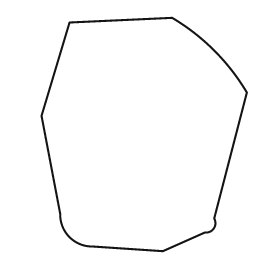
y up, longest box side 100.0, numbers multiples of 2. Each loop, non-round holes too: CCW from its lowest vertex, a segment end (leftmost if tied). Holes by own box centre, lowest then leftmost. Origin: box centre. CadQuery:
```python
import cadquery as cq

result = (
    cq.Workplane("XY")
    .moveTo(8.0, -50.0)
    .lineTo(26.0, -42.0)
    .threePointArc((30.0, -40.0), (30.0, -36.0))
    .lineTo(44.0, 18.0)
    .threePointArc((30.0, 36.0), (12.0, 50.0))
    .lineTo(-32.0, 48.0)
    .lineTo(-44.0, 8.0)
    .lineTo(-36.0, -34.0)
    .threePointArc((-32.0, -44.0), (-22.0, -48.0))
    .close()
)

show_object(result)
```